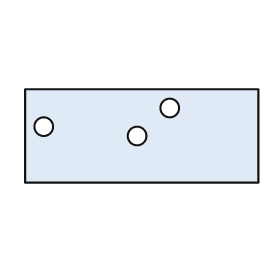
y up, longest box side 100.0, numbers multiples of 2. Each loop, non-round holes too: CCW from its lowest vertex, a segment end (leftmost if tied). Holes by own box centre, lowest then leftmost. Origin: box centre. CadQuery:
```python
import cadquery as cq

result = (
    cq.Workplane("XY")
    .moveTo(-50.0, -20.0)
    .lineTo(50.0, -20.0)
    .lineTo(50.0, 20.0)
    .lineTo(-50.0, 20.0)
    .close()
    .moveTo(-2.0, 0.0)
    .circle(4.0)
    .moveTo(-42.0, 4.0)
    .circle(4.0)
    .moveTo(12.0, 12.0)
    .circle(4.0)
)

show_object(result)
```